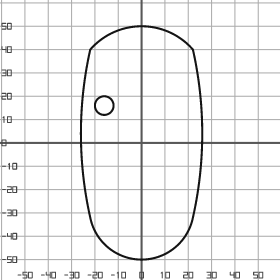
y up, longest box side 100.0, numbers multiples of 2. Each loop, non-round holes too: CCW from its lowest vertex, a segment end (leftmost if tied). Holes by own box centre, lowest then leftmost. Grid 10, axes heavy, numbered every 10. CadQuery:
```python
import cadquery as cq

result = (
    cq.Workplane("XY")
    .moveTo(-22.0, -32.0)
    .threePointArc((0.0, -50.0), (22.0, -32.0))
    .threePointArc((26.0, 4.0), (22.0, 40.0))
    .threePointArc((0.0, 50.0), (-22.0, 40.0))
    .threePointArc((-26.0, 4.0), (-22.0, -32.0))
    .close()
    .moveTo(-16.0, 16.0)
    .circle(4.0)
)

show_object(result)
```